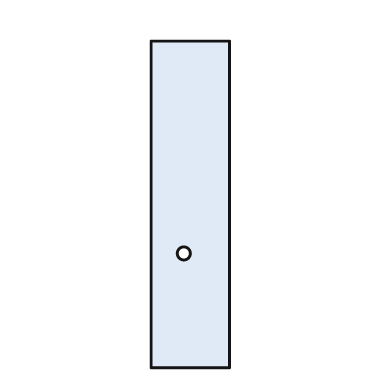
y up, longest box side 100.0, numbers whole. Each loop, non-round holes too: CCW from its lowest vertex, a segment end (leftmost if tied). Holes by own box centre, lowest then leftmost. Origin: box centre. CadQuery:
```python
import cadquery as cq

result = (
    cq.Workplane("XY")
    .moveTo(-12.0, -50.0)
    .lineTo(12.0, -50.0)
    .lineTo(12.0, 50.0)
    .lineTo(-12.0, 50.0)
    .close()
    .moveTo(-2.0, -15.0)
    .circle(2.0)
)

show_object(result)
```